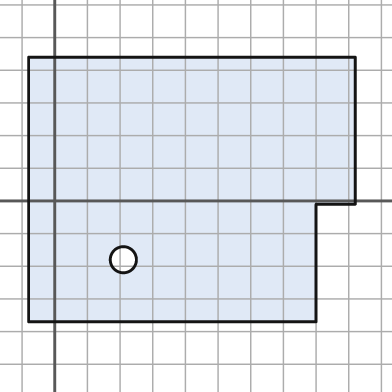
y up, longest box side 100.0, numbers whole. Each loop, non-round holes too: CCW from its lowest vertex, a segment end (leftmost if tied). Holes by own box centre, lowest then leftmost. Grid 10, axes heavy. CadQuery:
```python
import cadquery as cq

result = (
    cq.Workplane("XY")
    .moveTo(-8.0, -37.0)
    .lineTo(80.0, -37.0)
    .lineTo(80.0, -1.0)
    .lineTo(92.0, -1.0)
    .lineTo(92.0, 44.0)
    .lineTo(-8.0, 44.0)
    .close()
    .moveTo(21.0, -18.0)
    .circle(4.0)
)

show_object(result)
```